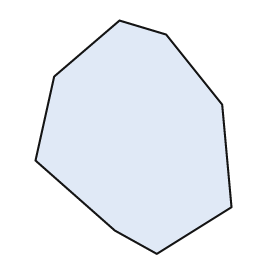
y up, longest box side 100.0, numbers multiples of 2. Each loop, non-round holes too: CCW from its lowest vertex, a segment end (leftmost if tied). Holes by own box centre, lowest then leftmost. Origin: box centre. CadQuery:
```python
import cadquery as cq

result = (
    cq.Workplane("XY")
    .moveTo(10.0, -50.0)
    .lineTo(42.0, -30.0)
    .lineTo(38.0, 14.0)
    .lineTo(14.0, 44.0)
    .lineTo(-6.0, 50.0)
    .lineTo(-34.0, 26.0)
    .lineTo(-42.0, -10.0)
    .lineTo(-8.0, -40.0)
    .close()
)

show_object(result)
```